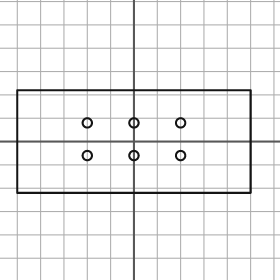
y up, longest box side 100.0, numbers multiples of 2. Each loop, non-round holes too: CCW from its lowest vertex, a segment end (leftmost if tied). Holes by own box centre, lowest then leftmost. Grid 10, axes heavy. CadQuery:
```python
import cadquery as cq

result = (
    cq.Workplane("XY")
    .moveTo(-50.0, -22.0)
    .lineTo(50.0, -22.0)
    .lineTo(50.0, 22.0)
    .lineTo(-50.0, 22.0)
    .close()
    .moveTo(-20.0, -6.0)
    .circle(2.0)
    .moveTo(0.0, -6.0)
    .circle(2.0)
    .moveTo(20.0, -6.0)
    .circle(2.0)
    .moveTo(-20.0, 8.0)
    .circle(2.0)
    .moveTo(0.0, 8.0)
    .circle(2.0)
    .moveTo(20.0, 8.0)
    .circle(2.0)
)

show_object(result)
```